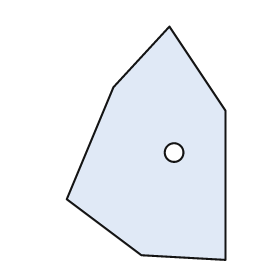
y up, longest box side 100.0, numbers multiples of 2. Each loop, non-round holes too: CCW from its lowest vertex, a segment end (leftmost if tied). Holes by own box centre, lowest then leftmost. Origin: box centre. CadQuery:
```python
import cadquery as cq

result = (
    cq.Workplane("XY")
    .moveTo(34.0, -50.0)
    .lineTo(34.0, 14.0)
    .lineTo(10.0, 50.0)
    .lineTo(-14.0, 24.0)
    .lineTo(-34.0, -24.0)
    .lineTo(-2.0, -48.0)
    .close()
    .moveTo(12.0, -4.0)
    .circle(4.0)
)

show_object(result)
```